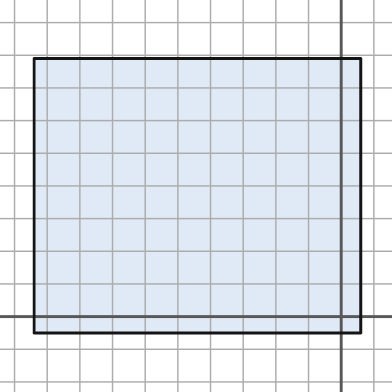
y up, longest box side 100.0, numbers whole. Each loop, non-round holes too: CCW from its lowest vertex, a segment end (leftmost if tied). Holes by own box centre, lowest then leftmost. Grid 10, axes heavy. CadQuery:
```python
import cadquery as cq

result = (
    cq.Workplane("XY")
    .moveTo(-94.0, -5.0)
    .lineTo(6.0, -5.0)
    .lineTo(6.0, 79.0)
    .lineTo(-94.0, 79.0)
    .close()
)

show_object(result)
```